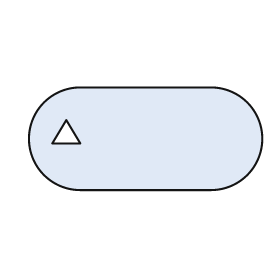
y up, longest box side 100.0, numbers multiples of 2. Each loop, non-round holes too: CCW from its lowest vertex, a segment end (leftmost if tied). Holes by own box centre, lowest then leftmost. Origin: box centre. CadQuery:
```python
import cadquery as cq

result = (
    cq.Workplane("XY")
    .moveTo(-28.0, -22.0)
    .lineTo(28.0, -22.0)
    .threePointArc((50.0, 0.0), (28.0, 22.0))
    .lineTo(-28.0, 22.0)
    .threePointArc((-50.0, 0.0), (-28.0, -22.0))
    .close()
    .moveTo(-40.0, -2.0)
    .lineTo(-28.0, -2.0)
    .lineTo(-34.0, 8.0)
    .close()
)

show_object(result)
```